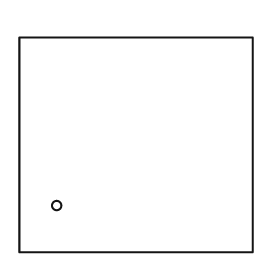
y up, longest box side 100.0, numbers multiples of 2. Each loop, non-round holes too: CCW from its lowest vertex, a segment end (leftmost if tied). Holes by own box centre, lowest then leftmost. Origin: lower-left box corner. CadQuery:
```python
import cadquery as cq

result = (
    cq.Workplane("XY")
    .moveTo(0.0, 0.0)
    .lineTo(100.0, 0.0)
    .lineTo(100.0, 92.0)
    .lineTo(0.0, 92.0)
    .close()
    .moveTo(16.0, 20.0)
    .circle(2.0)
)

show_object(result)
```